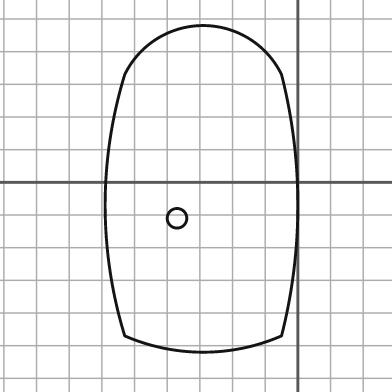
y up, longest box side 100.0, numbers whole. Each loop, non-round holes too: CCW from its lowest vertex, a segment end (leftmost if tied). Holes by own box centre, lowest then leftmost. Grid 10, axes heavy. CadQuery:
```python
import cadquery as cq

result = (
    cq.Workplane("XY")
    .moveTo(-53.0, -47.0)
    .threePointArc((-29.0, -52.0), (-5.0, -47.0))
    .threePointArc((0.0, -7.0), (-5.0, 33.0))
    .threePointArc((-29.0, 48.0), (-53.0, 33.0))
    .threePointArc((-59.0, -7.0), (-53.0, -47.0))
    .close()
    .moveTo(-37.0, -11.0)
    .circle(3.0)
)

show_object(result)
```